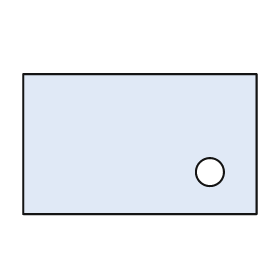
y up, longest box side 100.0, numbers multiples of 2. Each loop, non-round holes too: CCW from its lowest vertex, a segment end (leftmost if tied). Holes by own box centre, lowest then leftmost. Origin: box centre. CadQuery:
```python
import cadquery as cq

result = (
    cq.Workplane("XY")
    .moveTo(-50.0, -30.0)
    .lineTo(50.0, -30.0)
    .lineTo(50.0, 30.0)
    .lineTo(-50.0, 30.0)
    .close()
    .moveTo(30.0, -12.0)
    .circle(6.0)
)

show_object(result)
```